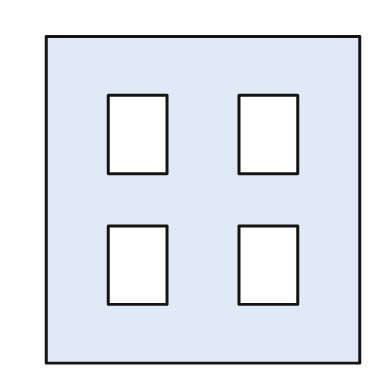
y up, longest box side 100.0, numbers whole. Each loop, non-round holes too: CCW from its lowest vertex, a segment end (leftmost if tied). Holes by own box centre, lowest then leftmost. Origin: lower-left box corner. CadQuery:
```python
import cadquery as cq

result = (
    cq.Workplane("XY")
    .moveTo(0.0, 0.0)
    .lineTo(96.0, 0.0)
    .lineTo(96.0, 100.0)
    .lineTo(0.0, 100.0)
    .close()
    .moveTo(19.0, 18.0)
    .lineTo(37.0, 18.0)
    .lineTo(37.0, 42.0)
    .lineTo(19.0, 42.0)
    .close()
    .moveTo(59.0, 18.0)
    .lineTo(77.0, 18.0)
    .lineTo(77.0, 42.0)
    .lineTo(59.0, 42.0)
    .close()
    .moveTo(19.0, 58.0)
    .lineTo(37.0, 58.0)
    .lineTo(37.0, 82.0)
    .lineTo(19.0, 82.0)
    .close()
    .moveTo(59.0, 58.0)
    .lineTo(77.0, 58.0)
    .lineTo(77.0, 82.0)
    .lineTo(59.0, 82.0)
    .close()
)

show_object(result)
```